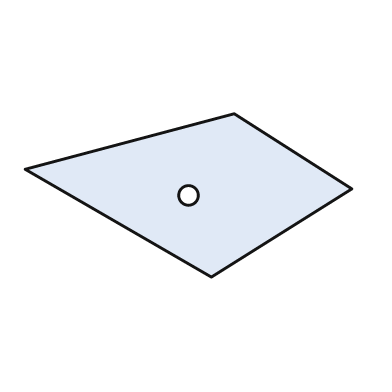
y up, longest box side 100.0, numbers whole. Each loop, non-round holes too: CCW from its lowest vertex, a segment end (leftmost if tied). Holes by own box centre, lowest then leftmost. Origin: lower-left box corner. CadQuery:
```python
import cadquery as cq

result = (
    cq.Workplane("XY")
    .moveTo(57.0, 0.0)
    .lineTo(100.0, 27.0)
    .lineTo(64.0, 50.0)
    .lineTo(0.0, 33.0)
    .close()
    .moveTo(50.0, 25.0)
    .circle(3.0)
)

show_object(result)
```